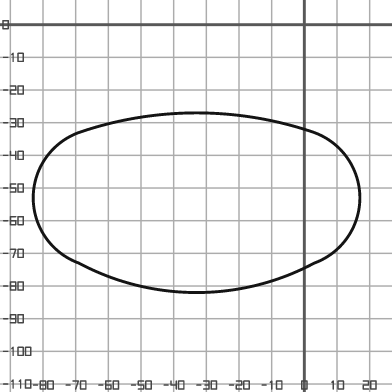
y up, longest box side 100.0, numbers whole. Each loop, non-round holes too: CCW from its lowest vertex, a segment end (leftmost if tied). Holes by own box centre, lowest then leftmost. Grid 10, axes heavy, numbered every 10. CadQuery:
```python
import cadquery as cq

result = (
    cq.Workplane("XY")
    .moveTo(-69.0, -73.0)
    .threePointArc((-33.0, -82.0), (3.0, -73.0))
    .threePointArc((17.0, -53.0), (3.0, -33.0))
    .threePointArc((-33.0, -27.0), (-69.0, -33.0))
    .threePointArc((-83.0, -53.0), (-69.0, -73.0))
    .close()
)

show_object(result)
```